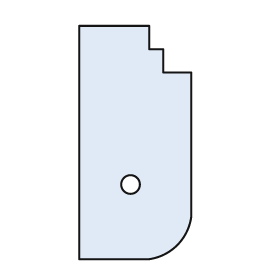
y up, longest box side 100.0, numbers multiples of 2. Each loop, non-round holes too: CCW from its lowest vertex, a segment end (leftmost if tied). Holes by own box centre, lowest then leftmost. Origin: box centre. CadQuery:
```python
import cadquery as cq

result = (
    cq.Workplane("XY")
    .moveTo(-24.0, -50.0)
    .lineTo(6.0, -50.0)
    .threePointArc((18.0, -44.0), (24.0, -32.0))
    .lineTo(24.0, 30.0)
    .lineTo(12.0, 30.0)
    .lineTo(12.0, 40.0)
    .lineTo(6.0, 40.0)
    .lineTo(6.0, 50.0)
    .lineTo(-24.0, 50.0)
    .close()
    .moveTo(-2.0, -18.0)
    .circle(4.0)
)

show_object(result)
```